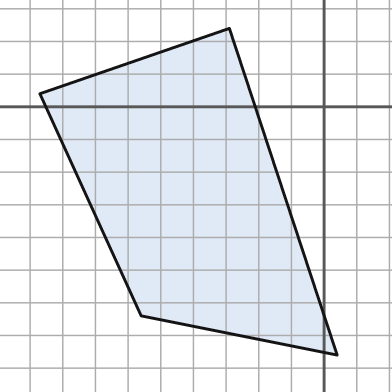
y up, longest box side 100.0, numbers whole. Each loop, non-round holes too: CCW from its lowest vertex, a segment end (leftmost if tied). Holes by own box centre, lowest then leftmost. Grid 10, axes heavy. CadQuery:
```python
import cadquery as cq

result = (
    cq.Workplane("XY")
    .moveTo(4.0, -76.0)
    .lineTo(-29.0, 24.0)
    .lineTo(-87.0, 4.0)
    .lineTo(-56.0, -64.0)
    .close()
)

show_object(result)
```